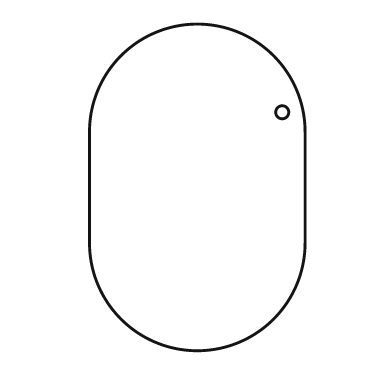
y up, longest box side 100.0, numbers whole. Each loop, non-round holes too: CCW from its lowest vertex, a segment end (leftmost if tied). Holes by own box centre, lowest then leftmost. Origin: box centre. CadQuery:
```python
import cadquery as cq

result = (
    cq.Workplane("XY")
    .moveTo(-33.0, -17.0)
    .threePointArc((0.0, -50.0), (33.0, -17.0))
    .lineTo(33.0, 17.0)
    .threePointArc((0.0, 50.0), (-33.0, 17.0))
    .close()
    .moveTo(26.0, 23.0)
    .circle(2.0)
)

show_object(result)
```